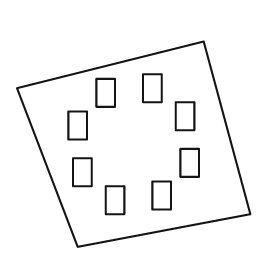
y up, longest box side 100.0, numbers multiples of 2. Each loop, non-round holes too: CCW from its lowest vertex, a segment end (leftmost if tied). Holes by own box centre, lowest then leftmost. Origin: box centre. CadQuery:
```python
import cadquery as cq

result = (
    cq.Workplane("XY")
    .moveTo(-24.0, -44.0)
    .lineTo(50.0, -30.0)
    .lineTo(30.0, 44.0)
    .lineTo(-50.0, 24.0)
    .close()
    .moveTo(-12.0, -30.0)
    .lineTo(-4.0, -30.0)
    .lineTo(-4.0, -18.0)
    .lineTo(-12.0, -18.0)
    .close()
    .moveTo(8.0, -28.0)
    .lineTo(16.0, -28.0)
    .lineTo(16.0, -16.0)
    .lineTo(8.0, -16.0)
    .close()
    .moveTo(-26.0, -18.0)
    .lineTo(-18.0, -18.0)
    .lineTo(-18.0, -6.0)
    .lineTo(-26.0, -6.0)
    .close()
    .moveTo(20.0, -14.0)
    .lineTo(28.0, -14.0)
    .lineTo(28.0, -2.0)
    .lineTo(20.0, -2.0)
    .close()
    .moveTo(-28.0, 2.0)
    .lineTo(-20.0, 2.0)
    .lineTo(-20.0, 14.0)
    .lineTo(-28.0, 14.0)
    .close()
    .moveTo(18.0, 6.0)
    .lineTo(26.0, 6.0)
    .lineTo(26.0, 18.0)
    .lineTo(18.0, 18.0)
    .close()
    .moveTo(-16.0, 16.0)
    .lineTo(-8.0, 16.0)
    .lineTo(-8.0, 28.0)
    .lineTo(-16.0, 28.0)
    .close()
    .moveTo(4.0, 18.0)
    .lineTo(12.0, 18.0)
    .lineTo(12.0, 30.0)
    .lineTo(4.0, 30.0)
    .close()
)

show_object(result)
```